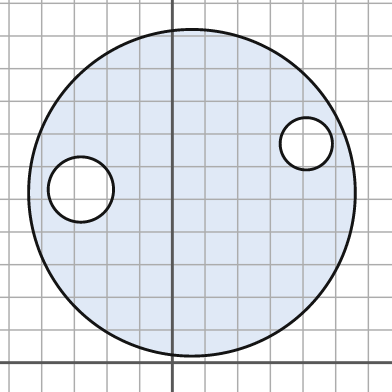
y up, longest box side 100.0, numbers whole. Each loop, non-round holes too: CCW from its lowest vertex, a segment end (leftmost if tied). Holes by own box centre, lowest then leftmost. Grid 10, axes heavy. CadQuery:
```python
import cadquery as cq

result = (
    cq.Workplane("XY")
    .moveTo(6.0, 52.0)
    .circle(50.0)
    .moveTo(-28.0, 53.0)
    .circle(10.0)
    .moveTo(41.0, 67.0)
    .circle(8.0)
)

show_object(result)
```